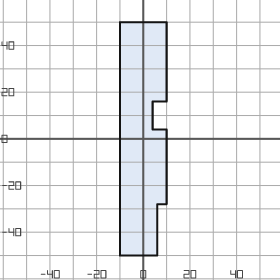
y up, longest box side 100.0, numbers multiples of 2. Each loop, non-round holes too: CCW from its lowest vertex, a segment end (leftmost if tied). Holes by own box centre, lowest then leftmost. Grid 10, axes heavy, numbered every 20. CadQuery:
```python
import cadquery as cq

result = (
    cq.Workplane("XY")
    .moveTo(-10.0, -50.0)
    .lineTo(6.0, -50.0)
    .lineTo(6.0, -28.0)
    .lineTo(10.0, -28.0)
    .lineTo(10.0, 4.0)
    .lineTo(4.0, 4.0)
    .lineTo(4.0, 16.0)
    .lineTo(10.0, 16.0)
    .lineTo(10.0, 50.0)
    .lineTo(-10.0, 50.0)
    .close()
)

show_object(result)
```